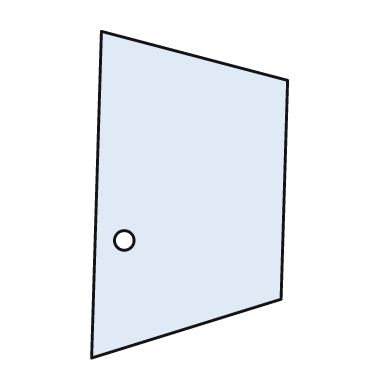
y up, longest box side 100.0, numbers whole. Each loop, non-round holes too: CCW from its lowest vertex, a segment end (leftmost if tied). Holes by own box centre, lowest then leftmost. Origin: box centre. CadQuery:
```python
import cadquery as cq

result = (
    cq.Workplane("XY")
    .moveTo(-30.0, -50.0)
    .lineTo(28.0, -32.0)
    .lineTo(30.0, 35.0)
    .lineTo(-27.0, 50.0)
    .close()
    .moveTo(-20.0, -14.0)
    .circle(3.0)
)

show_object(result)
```